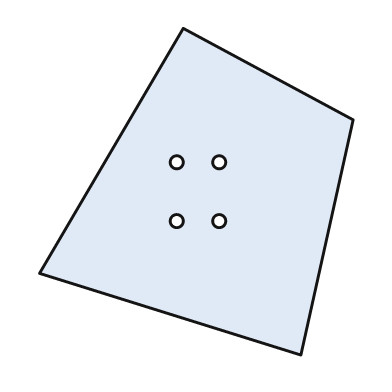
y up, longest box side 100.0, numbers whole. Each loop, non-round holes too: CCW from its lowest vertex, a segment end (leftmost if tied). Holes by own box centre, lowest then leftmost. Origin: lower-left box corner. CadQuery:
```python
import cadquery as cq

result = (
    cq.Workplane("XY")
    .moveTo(80.0, 0.0)
    .lineTo(96.0, 72.0)
    .lineTo(44.0, 100.0)
    .lineTo(0.0, 25.0)
    .close()
    .moveTo(42.0, 41.0)
    .circle(2.0)
    .moveTo(55.0, 41.0)
    .circle(2.0)
    .moveTo(42.0, 59.0)
    .circle(2.0)
    .moveTo(55.0, 59.0)
    .circle(2.0)
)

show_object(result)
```